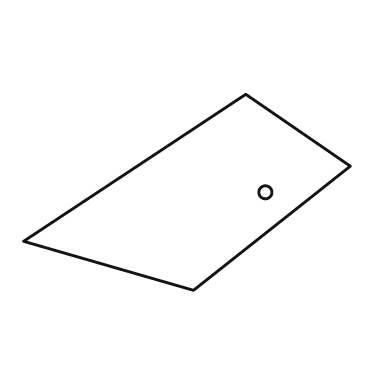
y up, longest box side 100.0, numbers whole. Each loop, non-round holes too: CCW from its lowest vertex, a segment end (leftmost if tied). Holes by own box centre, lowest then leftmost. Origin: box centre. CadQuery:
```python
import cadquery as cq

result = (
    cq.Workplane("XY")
    .moveTo(2.0, -30.0)
    .lineTo(50.0, 8.0)
    .lineTo(18.0, 30.0)
    .lineTo(-50.0, -15.0)
    .close()
    .moveTo(24.0, 0.0)
    .circle(2.0)
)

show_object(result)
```